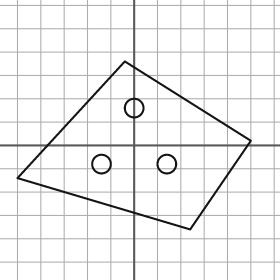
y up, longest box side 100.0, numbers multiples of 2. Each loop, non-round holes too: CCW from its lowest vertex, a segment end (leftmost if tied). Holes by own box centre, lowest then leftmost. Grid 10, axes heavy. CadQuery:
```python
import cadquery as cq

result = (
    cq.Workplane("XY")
    .moveTo(24.0, -36.0)
    .lineTo(50.0, 2.0)
    .lineTo(-4.0, 36.0)
    .lineTo(-50.0, -14.0)
    .close()
    .moveTo(-14.0, -8.0)
    .circle(4.0)
    .moveTo(14.0, -8.0)
    .circle(4.0)
    .moveTo(0.0, 16.0)
    .circle(4.0)
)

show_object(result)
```